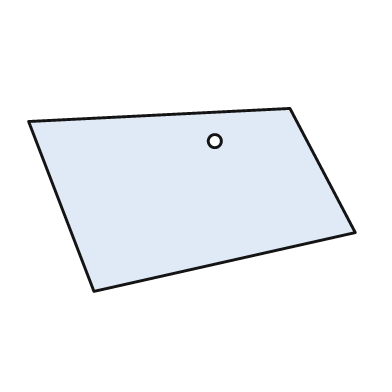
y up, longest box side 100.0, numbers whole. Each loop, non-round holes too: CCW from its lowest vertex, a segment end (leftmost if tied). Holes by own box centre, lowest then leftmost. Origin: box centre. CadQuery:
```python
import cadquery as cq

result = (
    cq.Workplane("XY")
    .moveTo(-30.0, -28.0)
    .lineTo(50.0, -10.0)
    .lineTo(30.0, 28.0)
    .lineTo(-50.0, 24.0)
    .close()
    .moveTo(7.0, 18.0)
    .circle(2.0)
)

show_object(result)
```